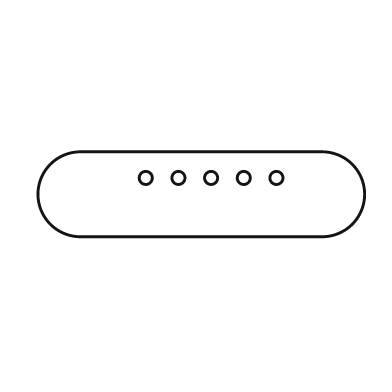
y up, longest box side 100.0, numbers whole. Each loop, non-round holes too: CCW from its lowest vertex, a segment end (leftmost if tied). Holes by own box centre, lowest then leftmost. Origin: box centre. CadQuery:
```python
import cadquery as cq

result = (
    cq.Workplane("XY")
    .moveTo(-37.0, -13.0)
    .lineTo(37.0, -13.0)
    .threePointArc((50.0, 0.0), (37.0, 13.0))
    .lineTo(-37.0, 13.0)
    .threePointArc((-50.0, 0.0), (-37.0, -13.0))
    .close()
    .moveTo(-17.0, 5.0)
    .circle(2.0)
    .moveTo(-7.0, 5.0)
    .circle(2.0)
    .moveTo(3.0, 5.0)
    .circle(2.0)
    .moveTo(13.0, 5.0)
    .circle(2.0)
    .moveTo(23.0, 5.0)
    .circle(2.0)
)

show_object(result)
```